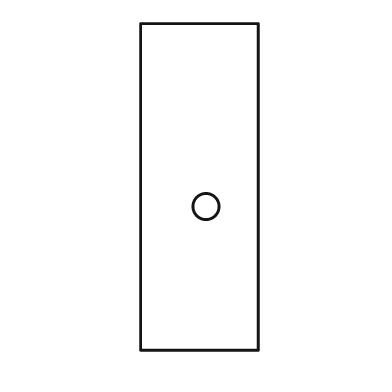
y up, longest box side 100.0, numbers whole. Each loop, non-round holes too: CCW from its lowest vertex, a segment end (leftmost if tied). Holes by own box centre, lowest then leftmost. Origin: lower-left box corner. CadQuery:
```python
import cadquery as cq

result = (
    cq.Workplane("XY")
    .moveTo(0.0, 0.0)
    .lineTo(36.0, 0.0)
    .lineTo(36.0, 100.0)
    .lineTo(0.0, 100.0)
    .close()
    .moveTo(20.0, 44.0)
    .circle(4.0)
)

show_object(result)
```